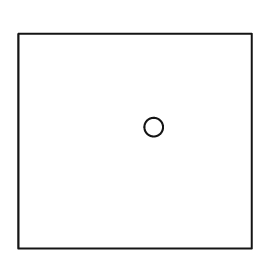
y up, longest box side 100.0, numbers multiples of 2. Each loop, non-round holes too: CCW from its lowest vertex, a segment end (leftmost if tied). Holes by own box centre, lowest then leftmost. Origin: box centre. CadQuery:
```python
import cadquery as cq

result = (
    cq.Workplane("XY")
    .moveTo(-50.0, -46.0)
    .lineTo(50.0, -46.0)
    .lineTo(50.0, 46.0)
    .lineTo(-50.0, 46.0)
    .close()
    .moveTo(8.0, 6.0)
    .circle(4.0)
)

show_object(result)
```